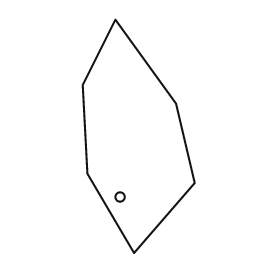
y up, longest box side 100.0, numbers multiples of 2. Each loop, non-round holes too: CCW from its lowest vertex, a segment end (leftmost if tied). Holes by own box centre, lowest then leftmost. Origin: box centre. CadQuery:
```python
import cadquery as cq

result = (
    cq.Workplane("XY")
    .moveTo(-2.0, -50.0)
    .lineTo(24.0, -20.0)
    .lineTo(16.0, 14.0)
    .lineTo(-10.0, 50.0)
    .lineTo(-24.0, 22.0)
    .lineTo(-22.0, -16.0)
    .close()
    .moveTo(-8.0, -26.0)
    .circle(2.0)
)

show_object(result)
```